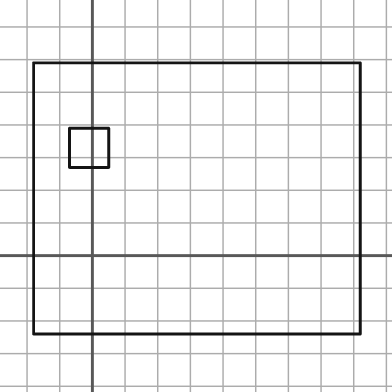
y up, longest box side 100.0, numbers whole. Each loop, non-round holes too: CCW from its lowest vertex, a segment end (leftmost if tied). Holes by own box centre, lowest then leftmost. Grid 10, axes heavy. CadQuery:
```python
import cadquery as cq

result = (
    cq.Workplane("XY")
    .moveTo(-18.0, -24.0)
    .lineTo(82.0, -24.0)
    .lineTo(82.0, 59.0)
    .lineTo(-18.0, 59.0)
    .close()
    .moveTo(-7.0, 27.0)
    .lineTo(5.0, 27.0)
    .lineTo(5.0, 39.0)
    .lineTo(-7.0, 39.0)
    .close()
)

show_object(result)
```